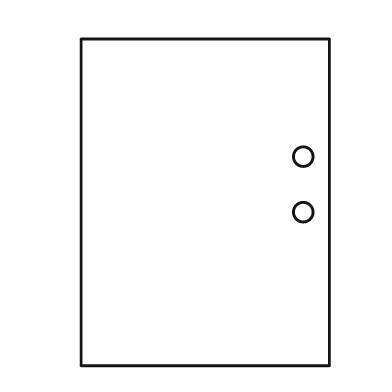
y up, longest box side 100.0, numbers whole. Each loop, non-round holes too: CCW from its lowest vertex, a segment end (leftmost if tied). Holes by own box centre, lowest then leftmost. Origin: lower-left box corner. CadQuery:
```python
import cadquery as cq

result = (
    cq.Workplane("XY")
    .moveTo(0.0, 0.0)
    .lineTo(76.0, 0.0)
    .lineTo(76.0, 100.0)
    .lineTo(0.0, 100.0)
    .close()
    .moveTo(68.0, 47.0)
    .circle(3.0)
    .moveTo(68.0, 64.0)
    .circle(3.0)
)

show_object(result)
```